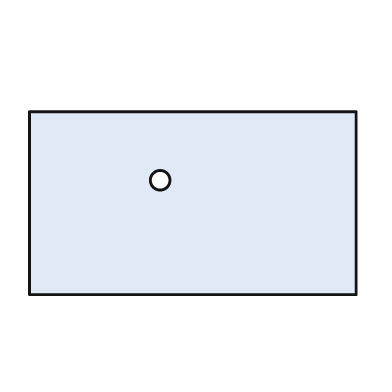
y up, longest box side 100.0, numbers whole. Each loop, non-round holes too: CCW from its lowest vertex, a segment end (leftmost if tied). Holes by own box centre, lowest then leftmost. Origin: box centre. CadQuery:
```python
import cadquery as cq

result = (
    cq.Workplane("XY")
    .moveTo(-50.0, -28.0)
    .lineTo(50.0, -28.0)
    .lineTo(50.0, 28.0)
    .lineTo(-50.0, 28.0)
    .close()
    .moveTo(-10.0, 7.0)
    .circle(3.0)
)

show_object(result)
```